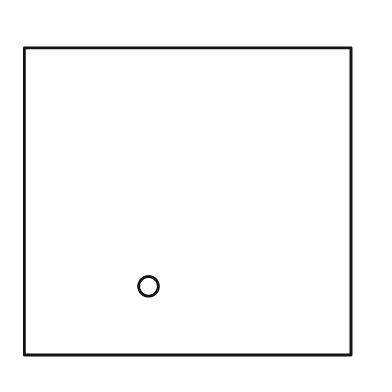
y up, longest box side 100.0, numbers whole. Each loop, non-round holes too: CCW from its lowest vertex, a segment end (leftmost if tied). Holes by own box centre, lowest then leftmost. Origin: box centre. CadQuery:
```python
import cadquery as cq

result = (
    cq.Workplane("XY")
    .moveTo(-50.0, -47.0)
    .lineTo(50.0, -47.0)
    .lineTo(50.0, 47.0)
    .lineTo(-50.0, 47.0)
    .close()
    .moveTo(-12.0, -26.0)
    .circle(3.0)
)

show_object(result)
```